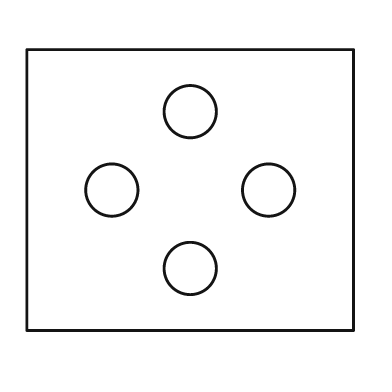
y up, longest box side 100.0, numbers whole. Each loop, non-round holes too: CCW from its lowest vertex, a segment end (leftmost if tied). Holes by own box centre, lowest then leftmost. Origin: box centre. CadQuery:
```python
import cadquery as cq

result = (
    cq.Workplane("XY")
    .moveTo(-50.0, -43.0)
    .lineTo(50.0, -43.0)
    .lineTo(50.0, 43.0)
    .lineTo(-50.0, 43.0)
    .close()
    .moveTo(0.0, -24.0)
    .circle(8.0)
    .moveTo(-24.0, 0.0)
    .circle(8.0)
    .moveTo(24.0, 0.0)
    .circle(8.0)
    .moveTo(0.0, 24.0)
    .circle(8.0)
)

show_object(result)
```